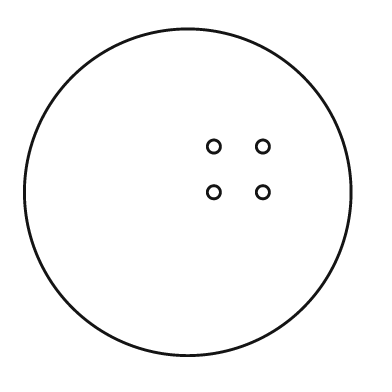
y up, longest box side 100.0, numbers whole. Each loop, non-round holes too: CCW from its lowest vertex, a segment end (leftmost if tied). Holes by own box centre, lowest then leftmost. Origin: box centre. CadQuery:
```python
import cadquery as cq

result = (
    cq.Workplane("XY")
    .moveTo(0.0, 0.0)
    .circle(50.0)
    .moveTo(8.0, 0.0)
    .circle(2.0)
    .moveTo(23.0, 0.0)
    .circle(2.0)
    .moveTo(8.0, 14.0)
    .circle(2.0)
    .moveTo(23.0, 14.0)
    .circle(2.0)
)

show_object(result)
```